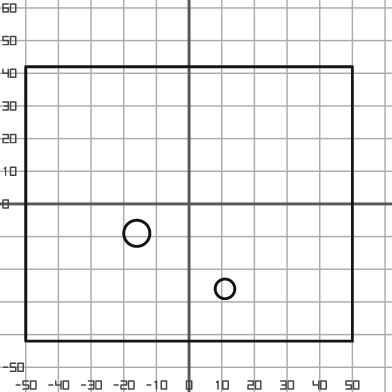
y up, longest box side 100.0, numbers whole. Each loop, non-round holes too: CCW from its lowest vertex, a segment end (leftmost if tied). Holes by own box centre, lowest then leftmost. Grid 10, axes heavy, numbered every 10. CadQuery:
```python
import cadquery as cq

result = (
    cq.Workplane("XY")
    .moveTo(-50.0, -42.0)
    .lineTo(50.0, -42.0)
    .lineTo(50.0, 42.0)
    .lineTo(-50.0, 42.0)
    .close()
    .moveTo(11.0, -26.0)
    .circle(3.0)
    .moveTo(-16.0, -9.0)
    .circle(4.0)
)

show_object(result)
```